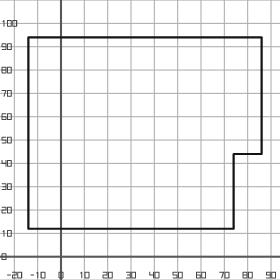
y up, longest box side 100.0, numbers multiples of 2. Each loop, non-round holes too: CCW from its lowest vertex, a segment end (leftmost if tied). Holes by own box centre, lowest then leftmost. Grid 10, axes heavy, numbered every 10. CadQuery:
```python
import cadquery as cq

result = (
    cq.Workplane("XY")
    .moveTo(-14.0, 12.0)
    .lineTo(74.0, 12.0)
    .lineTo(74.0, 44.0)
    .lineTo(86.0, 44.0)
    .lineTo(86.0, 94.0)
    .lineTo(-14.0, 94.0)
    .close()
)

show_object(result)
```